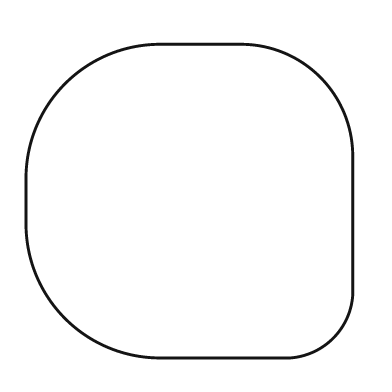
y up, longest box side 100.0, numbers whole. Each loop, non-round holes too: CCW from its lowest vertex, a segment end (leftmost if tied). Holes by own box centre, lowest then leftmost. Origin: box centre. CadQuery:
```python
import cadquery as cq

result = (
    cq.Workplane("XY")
    .moveTo(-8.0, -48.0)
    .lineTo(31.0, -48.0)
    .threePointArc((44.0, -42.0), (50.0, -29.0))
    .lineTo(50.0, 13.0)
    .threePointArc((40.0, 38.0), (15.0, 48.0))
    .lineTo(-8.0, 48.0)
    .threePointArc((-38.0, 36.0), (-50.0, 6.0))
    .lineTo(-50.0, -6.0)
    .threePointArc((-38.0, -36.0), (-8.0, -48.0))
    .close()
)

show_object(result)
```